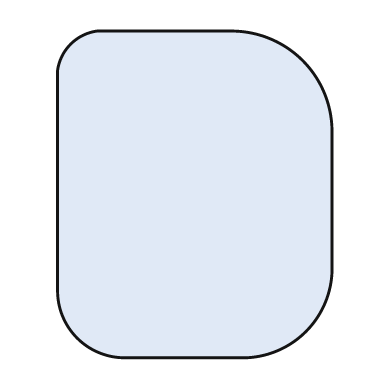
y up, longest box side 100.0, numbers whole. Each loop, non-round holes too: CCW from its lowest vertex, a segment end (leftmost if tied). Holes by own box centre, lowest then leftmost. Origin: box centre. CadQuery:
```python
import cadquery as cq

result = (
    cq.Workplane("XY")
    .moveTo(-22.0, -50.0)
    .lineTo(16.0, -50.0)
    .threePointArc((34.0, -42.0), (42.0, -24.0))
    .lineTo(42.0, 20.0)
    .threePointArc((33.0, 41.0), (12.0, 50.0))
    .lineTo(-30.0, 50.0)
    .threePointArc((-38.0, 46.0), (-42.0, 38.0))
    .lineTo(-42.0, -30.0)
    .threePointArc((-36.0, -44.0), (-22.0, -50.0))
    .close()
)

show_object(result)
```